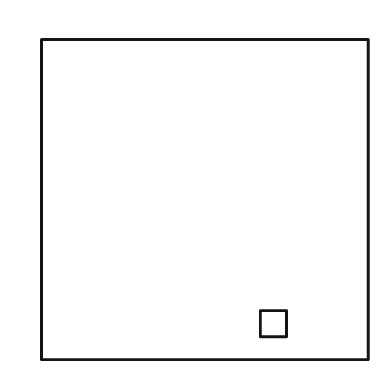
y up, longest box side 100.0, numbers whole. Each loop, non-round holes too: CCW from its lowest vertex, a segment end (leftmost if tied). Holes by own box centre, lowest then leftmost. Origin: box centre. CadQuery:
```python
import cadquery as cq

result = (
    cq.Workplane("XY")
    .moveTo(-50.0, -49.0)
    .lineTo(50.0, -49.0)
    .lineTo(50.0, 49.0)
    .lineTo(-50.0, 49.0)
    .close()
    .moveTo(17.0, -42.0)
    .lineTo(25.0, -42.0)
    .lineTo(25.0, -34.0)
    .lineTo(17.0, -34.0)
    .close()
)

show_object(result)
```